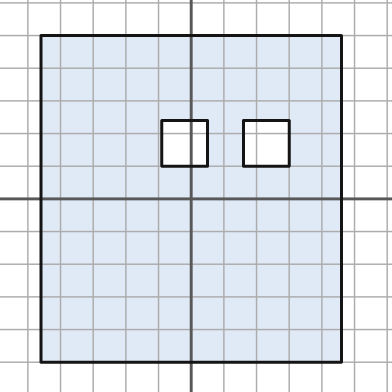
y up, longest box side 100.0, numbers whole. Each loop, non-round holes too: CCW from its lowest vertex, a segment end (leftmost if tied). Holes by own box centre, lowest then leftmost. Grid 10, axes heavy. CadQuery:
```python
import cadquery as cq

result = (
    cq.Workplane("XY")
    .moveTo(-46.0, -50.0)
    .lineTo(46.0, -50.0)
    .lineTo(46.0, 50.0)
    .lineTo(-46.0, 50.0)
    .close()
    .moveTo(-9.0, 10.0)
    .lineTo(5.0, 10.0)
    .lineTo(5.0, 24.0)
    .lineTo(-9.0, 24.0)
    .close()
    .moveTo(16.0, 10.0)
    .lineTo(30.0, 10.0)
    .lineTo(30.0, 24.0)
    .lineTo(16.0, 24.0)
    .close()
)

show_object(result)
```